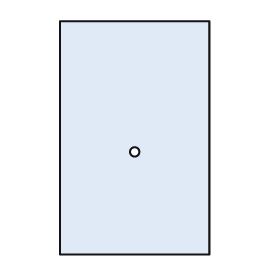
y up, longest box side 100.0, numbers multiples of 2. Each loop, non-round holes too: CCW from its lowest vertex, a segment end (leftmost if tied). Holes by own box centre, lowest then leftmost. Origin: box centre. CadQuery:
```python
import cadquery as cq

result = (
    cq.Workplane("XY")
    .moveTo(-32.0, -50.0)
    .lineTo(32.0, -50.0)
    .lineTo(32.0, 50.0)
    .lineTo(-32.0, 50.0)
    .close()
    .moveTo(0.0, -6.0)
    .circle(2.0)
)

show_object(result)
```